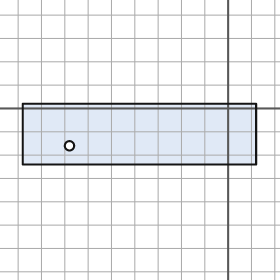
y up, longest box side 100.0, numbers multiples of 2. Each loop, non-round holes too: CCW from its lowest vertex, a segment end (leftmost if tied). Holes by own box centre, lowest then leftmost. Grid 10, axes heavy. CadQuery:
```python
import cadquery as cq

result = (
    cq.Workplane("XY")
    .moveTo(-88.0, -24.0)
    .lineTo(12.0, -24.0)
    .lineTo(12.0, 2.0)
    .lineTo(-88.0, 2.0)
    .close()
    .moveTo(-68.0, -16.0)
    .circle(2.0)
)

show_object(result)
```